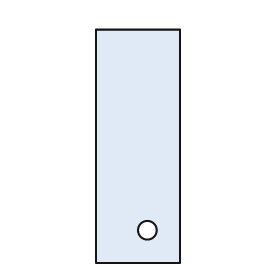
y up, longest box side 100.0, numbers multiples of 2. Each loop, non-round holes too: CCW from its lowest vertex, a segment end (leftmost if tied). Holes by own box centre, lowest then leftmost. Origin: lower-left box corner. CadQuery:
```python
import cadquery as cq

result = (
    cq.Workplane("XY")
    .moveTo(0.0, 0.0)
    .lineTo(36.0, 0.0)
    .lineTo(36.0, 100.0)
    .lineTo(0.0, 100.0)
    .close()
    .moveTo(22.0, 14.0)
    .circle(4.0)
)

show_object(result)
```